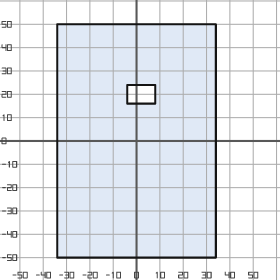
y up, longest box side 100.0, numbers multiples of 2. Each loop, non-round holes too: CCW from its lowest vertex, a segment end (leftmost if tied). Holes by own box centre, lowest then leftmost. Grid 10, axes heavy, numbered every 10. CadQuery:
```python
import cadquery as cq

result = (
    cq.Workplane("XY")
    .moveTo(-34.0, -50.0)
    .lineTo(34.0, -50.0)
    .lineTo(34.0, 50.0)
    .lineTo(-34.0, 50.0)
    .close()
    .moveTo(-4.0, 16.0)
    .lineTo(8.0, 16.0)
    .lineTo(8.0, 24.0)
    .lineTo(-4.0, 24.0)
    .close()
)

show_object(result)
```